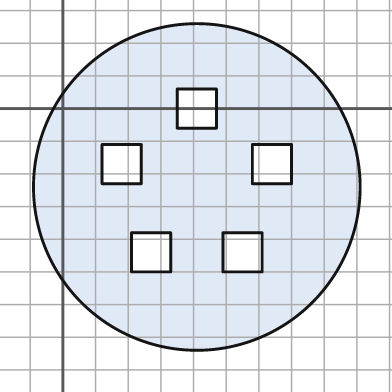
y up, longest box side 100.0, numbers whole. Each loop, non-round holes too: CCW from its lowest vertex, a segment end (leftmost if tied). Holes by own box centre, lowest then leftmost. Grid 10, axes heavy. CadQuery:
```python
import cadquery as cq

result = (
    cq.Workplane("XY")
    .moveTo(41.0, -24.0)
    .circle(50.0)
    .moveTo(21.0, -50.0)
    .lineTo(33.0, -50.0)
    .lineTo(33.0, -38.0)
    .lineTo(21.0, -38.0)
    .close()
    .moveTo(49.0, -50.0)
    .lineTo(61.0, -50.0)
    .lineTo(61.0, -38.0)
    .lineTo(49.0, -38.0)
    .close()
    .moveTo(12.0, -23.0)
    .lineTo(24.0, -23.0)
    .lineTo(24.0, -11.0)
    .lineTo(12.0, -11.0)
    .close()
    .moveTo(58.0, -23.0)
    .lineTo(70.0, -23.0)
    .lineTo(70.0, -11.0)
    .lineTo(58.0, -11.0)
    .close()
    .moveTo(35.0, -6.0)
    .lineTo(47.0, -6.0)
    .lineTo(47.0, 6.0)
    .lineTo(35.0, 6.0)
    .close()
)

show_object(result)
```